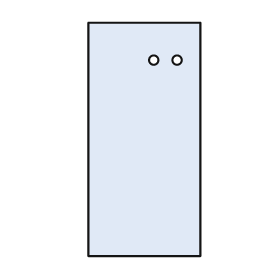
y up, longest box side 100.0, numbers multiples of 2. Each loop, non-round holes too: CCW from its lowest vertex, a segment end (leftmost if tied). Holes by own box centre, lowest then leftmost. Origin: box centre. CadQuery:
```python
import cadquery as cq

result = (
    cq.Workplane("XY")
    .moveTo(-24.0, -50.0)
    .lineTo(24.0, -50.0)
    .lineTo(24.0, 50.0)
    .lineTo(-24.0, 50.0)
    .close()
    .moveTo(4.0, 34.0)
    .circle(2.0)
    .moveTo(14.0, 34.0)
    .circle(2.0)
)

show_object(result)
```